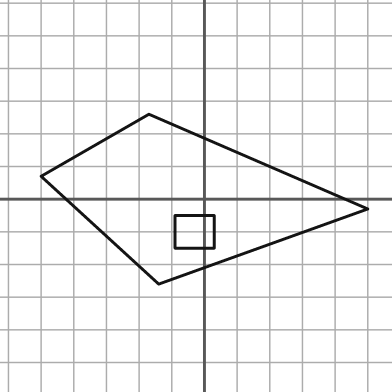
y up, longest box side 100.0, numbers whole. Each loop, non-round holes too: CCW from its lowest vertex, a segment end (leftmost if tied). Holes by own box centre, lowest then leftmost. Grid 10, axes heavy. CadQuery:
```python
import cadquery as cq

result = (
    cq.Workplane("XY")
    .moveTo(-14.0, -26.0)
    .lineTo(50.0, -3.0)
    .lineTo(-17.0, 26.0)
    .lineTo(-50.0, 7.0)
    .close()
    .moveTo(-9.0, -15.0)
    .lineTo(3.0, -15.0)
    .lineTo(3.0, -5.0)
    .lineTo(-9.0, -5.0)
    .close()
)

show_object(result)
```